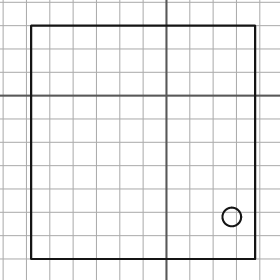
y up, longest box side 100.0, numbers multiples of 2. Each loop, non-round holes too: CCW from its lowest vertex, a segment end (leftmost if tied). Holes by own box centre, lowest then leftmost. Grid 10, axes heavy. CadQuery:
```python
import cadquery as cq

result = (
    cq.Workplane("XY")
    .moveTo(-58.0, -70.0)
    .lineTo(38.0, -70.0)
    .lineTo(38.0, 30.0)
    .lineTo(-58.0, 30.0)
    .close()
    .moveTo(28.0, -52.0)
    .circle(4.0)
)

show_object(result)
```